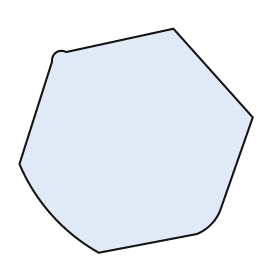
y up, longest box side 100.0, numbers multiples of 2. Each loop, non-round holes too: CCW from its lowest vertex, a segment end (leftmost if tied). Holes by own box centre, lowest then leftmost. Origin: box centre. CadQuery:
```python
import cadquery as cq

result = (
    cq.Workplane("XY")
    .moveTo(-16.0, -48.0)
    .lineTo(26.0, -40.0)
    .threePointArc((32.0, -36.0), (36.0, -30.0))
    .lineTo(50.0, 10.0)
    .lineTo(16.0, 48.0)
    .lineTo(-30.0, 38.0)
    .threePointArc((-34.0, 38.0), (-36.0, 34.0))
    .lineTo(-50.0, -10.0)
    .threePointArc((-36.0, -32.0), (-16.0, -48.0))
    .close()
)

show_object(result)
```